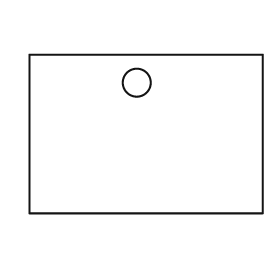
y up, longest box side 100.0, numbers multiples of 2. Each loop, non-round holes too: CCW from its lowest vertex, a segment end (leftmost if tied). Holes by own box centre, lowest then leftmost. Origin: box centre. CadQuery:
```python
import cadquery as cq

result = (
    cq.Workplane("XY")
    .moveTo(-50.0, -34.0)
    .lineTo(50.0, -34.0)
    .lineTo(50.0, 34.0)
    .lineTo(-50.0, 34.0)
    .close()
    .moveTo(-4.0, 22.0)
    .circle(6.0)
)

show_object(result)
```